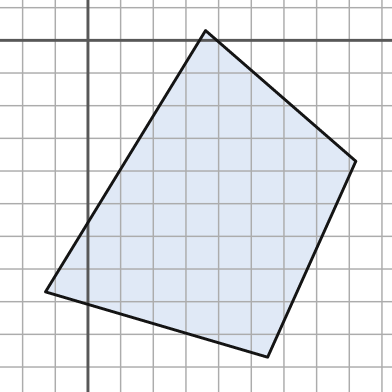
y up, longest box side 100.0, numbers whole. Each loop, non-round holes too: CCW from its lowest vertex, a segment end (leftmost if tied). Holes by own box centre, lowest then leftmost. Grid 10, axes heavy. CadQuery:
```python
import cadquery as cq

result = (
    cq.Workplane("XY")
    .moveTo(55.0, -97.0)
    .lineTo(82.0, -37.0)
    .lineTo(36.0, 3.0)
    .lineTo(-13.0, -77.0)
    .close()
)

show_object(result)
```